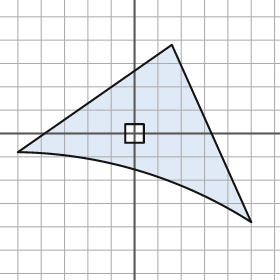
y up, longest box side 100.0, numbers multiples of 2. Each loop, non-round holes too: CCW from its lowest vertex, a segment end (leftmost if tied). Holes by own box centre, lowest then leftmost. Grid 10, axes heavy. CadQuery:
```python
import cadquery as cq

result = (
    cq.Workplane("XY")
    .moveTo(50.0, -38.0)
    .lineTo(16.0, 38.0)
    .lineTo(-50.0, -8.0)
    .threePointArc((2.0, -16.0), (50.0, -38.0))
    .close()
    .moveTo(-4.0, -4.0)
    .lineTo(4.0, -4.0)
    .lineTo(4.0, 4.0)
    .lineTo(-4.0, 4.0)
    .close()
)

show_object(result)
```